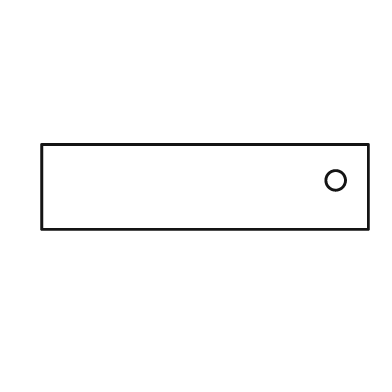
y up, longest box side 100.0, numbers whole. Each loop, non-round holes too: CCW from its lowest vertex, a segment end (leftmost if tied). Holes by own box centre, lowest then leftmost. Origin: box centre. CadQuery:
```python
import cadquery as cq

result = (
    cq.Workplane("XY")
    .moveTo(-50.0, -13.0)
    .lineTo(50.0, -13.0)
    .lineTo(50.0, 13.0)
    .lineTo(-50.0, 13.0)
    .close()
    .moveTo(40.0, 2.0)
    .circle(3.0)
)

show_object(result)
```